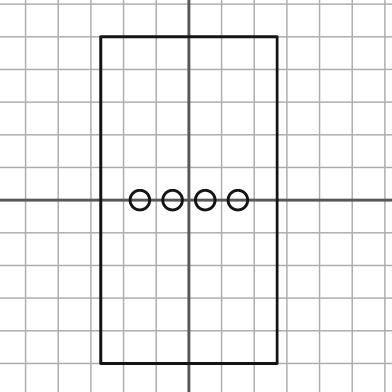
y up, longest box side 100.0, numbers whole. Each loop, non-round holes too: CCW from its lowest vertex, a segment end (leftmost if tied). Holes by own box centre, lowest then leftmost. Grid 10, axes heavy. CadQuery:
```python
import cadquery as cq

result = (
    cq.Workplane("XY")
    .moveTo(-27.0, -50.0)
    .lineTo(27.0, -50.0)
    .lineTo(27.0, 50.0)
    .lineTo(-27.0, 50.0)
    .close()
    .moveTo(-15.0, 0.0)
    .circle(3.0)
    .moveTo(-5.0, 0.0)
    .circle(3.0)
    .moveTo(5.0, 0.0)
    .circle(3.0)
    .moveTo(15.0, 0.0)
    .circle(3.0)
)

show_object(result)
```